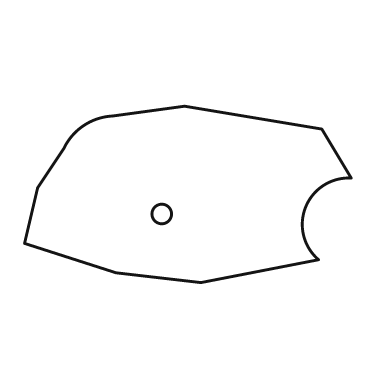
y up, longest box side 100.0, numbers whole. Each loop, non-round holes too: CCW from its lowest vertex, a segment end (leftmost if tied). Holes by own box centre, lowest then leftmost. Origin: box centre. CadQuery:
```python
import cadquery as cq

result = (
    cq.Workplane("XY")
    .moveTo(4.0, -27.0)
    .lineTo(40.0, -20.0)
    .threePointArc((36.0, -4.0), (50.0, 5.0))
    .lineTo(41.0, 20.0)
    .lineTo(-1.0, 27.0)
    .lineTo(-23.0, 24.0)
    .threePointArc((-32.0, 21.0), (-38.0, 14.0))
    .lineTo(-46.0, 2.0)
    .lineTo(-50.0, -15.0)
    .lineTo(-22.0, -24.0)
    .close()
    .moveTo(-8.0, -6.0)
    .circle(3.0)
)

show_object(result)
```